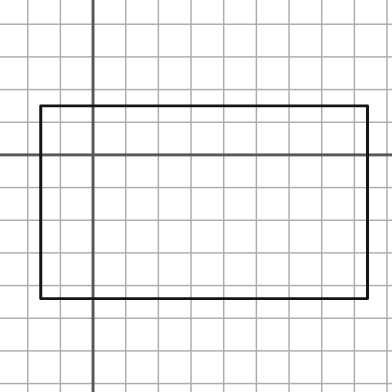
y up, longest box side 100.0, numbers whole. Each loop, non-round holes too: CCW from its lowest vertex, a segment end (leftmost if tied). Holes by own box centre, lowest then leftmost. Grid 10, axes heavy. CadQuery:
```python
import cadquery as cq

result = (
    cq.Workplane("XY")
    .moveTo(-16.0, -44.0)
    .lineTo(84.0, -44.0)
    .lineTo(84.0, 15.0)
    .lineTo(-16.0, 15.0)
    .close()
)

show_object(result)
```